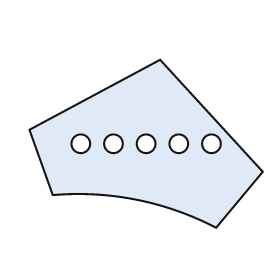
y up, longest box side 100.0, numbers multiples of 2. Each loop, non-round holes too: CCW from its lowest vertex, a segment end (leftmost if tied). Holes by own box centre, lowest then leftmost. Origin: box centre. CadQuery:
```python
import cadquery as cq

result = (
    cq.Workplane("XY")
    .moveTo(30.0, -36.0)
    .lineTo(50.0, -12.0)
    .lineTo(6.0, 36.0)
    .lineTo(-50.0, 6.0)
    .lineTo(-40.0, -22.0)
    .threePointArc((-4.0, -24.0), (30.0, -36.0))
    .close()
    .moveTo(-28.0, 0.0)
    .circle(4.0)
    .moveTo(-14.0, 0.0)
    .circle(4.0)
    .moveTo(0.0, 0.0)
    .circle(4.0)
    .moveTo(14.0, 0.0)
    .circle(4.0)
    .moveTo(28.0, 0.0)
    .circle(4.0)
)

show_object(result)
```